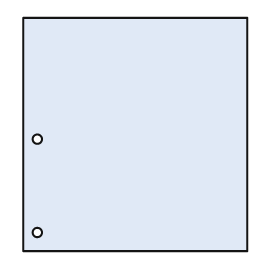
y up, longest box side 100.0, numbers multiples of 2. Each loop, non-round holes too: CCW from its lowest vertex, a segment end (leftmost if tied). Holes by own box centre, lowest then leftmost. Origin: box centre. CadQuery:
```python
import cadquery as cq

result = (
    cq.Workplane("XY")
    .moveTo(-48.0, -50.0)
    .lineTo(48.0, -50.0)
    .lineTo(48.0, 50.0)
    .lineTo(-48.0, 50.0)
    .close()
    .moveTo(-42.0, -42.0)
    .circle(2.0)
    .moveTo(-42.0, -2.0)
    .circle(2.0)
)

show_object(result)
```